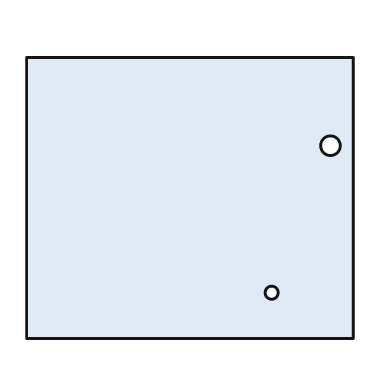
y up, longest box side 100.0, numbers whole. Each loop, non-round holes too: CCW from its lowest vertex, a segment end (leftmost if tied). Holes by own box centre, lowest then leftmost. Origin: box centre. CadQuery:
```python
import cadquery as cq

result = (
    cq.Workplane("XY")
    .moveTo(-50.0, -43.0)
    .lineTo(50.0, -43.0)
    .lineTo(50.0, 43.0)
    .lineTo(-50.0, 43.0)
    .close()
    .moveTo(25.0, -29.0)
    .circle(2.0)
    .moveTo(43.0, 16.0)
    .circle(3.0)
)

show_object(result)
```